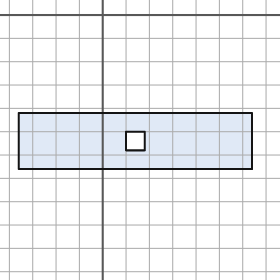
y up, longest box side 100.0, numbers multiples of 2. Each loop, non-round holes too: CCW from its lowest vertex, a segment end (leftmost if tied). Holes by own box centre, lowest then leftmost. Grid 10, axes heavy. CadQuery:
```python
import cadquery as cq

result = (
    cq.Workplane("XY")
    .moveTo(-36.0, -66.0)
    .lineTo(64.0, -66.0)
    .lineTo(64.0, -42.0)
    .lineTo(-36.0, -42.0)
    .close()
    .moveTo(10.0, -58.0)
    .lineTo(18.0, -58.0)
    .lineTo(18.0, -50.0)
    .lineTo(10.0, -50.0)
    .close()
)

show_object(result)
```